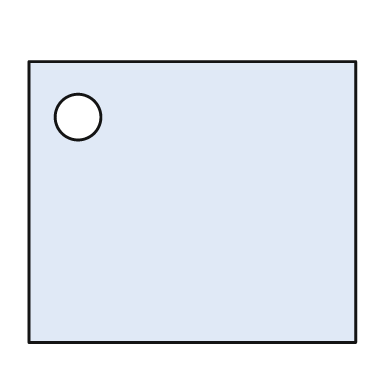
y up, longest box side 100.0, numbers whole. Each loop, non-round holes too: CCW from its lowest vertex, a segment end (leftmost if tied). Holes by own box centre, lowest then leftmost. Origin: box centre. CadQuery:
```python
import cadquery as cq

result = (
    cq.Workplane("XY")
    .moveTo(-50.0, -43.0)
    .lineTo(50.0, -43.0)
    .lineTo(50.0, 43.0)
    .lineTo(-50.0, 43.0)
    .close()
    .moveTo(-35.0, 26.0)
    .circle(7.0)
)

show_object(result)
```